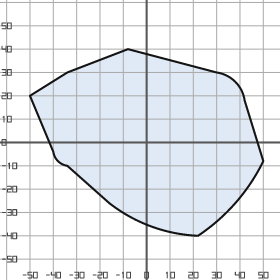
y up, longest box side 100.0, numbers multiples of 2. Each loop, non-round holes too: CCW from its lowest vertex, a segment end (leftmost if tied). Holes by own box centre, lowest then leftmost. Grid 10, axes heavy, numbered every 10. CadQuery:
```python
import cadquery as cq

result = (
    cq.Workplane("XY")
    .moveTo(22.0, -40.0)
    .threePointArc((38.0, -26.0), (50.0, -8.0))
    .lineTo(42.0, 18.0)
    .threePointArc((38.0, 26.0), (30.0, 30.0))
    .lineTo(-8.0, 40.0)
    .lineTo(-34.0, 30.0)
    .lineTo(-50.0, 20.0)
    .lineTo(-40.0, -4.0)
    .threePointArc((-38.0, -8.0), (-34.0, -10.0))
    .lineTo(-16.0, -26.0)
    .threePointArc((2.0, -36.0), (22.0, -40.0))
    .close()
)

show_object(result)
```